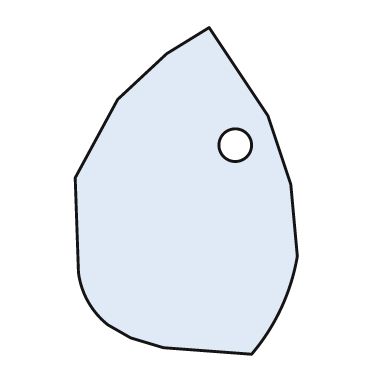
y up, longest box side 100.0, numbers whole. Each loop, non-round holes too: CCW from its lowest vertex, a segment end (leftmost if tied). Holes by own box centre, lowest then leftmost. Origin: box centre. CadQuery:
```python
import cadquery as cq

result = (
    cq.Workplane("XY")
    .moveTo(20.0, -50.0)
    .threePointArc((29.0, -36.0), (34.0, -20.0))
    .lineTo(32.0, 2.0)
    .lineTo(25.0, 23.0)
    .lineTo(7.0, 50.0)
    .lineTo(-6.0, 42.0)
    .lineTo(-21.0, 28.0)
    .lineTo(-34.0, 4.0)
    .lineTo(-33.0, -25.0)
    .threePointArc((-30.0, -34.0), (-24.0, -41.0))
    .lineTo(-17.0, -45.0)
    .lineTo(-7.0, -48.0)
    .close()
    .moveTo(15.0, 14.0)
    .circle(5.0)
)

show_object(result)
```